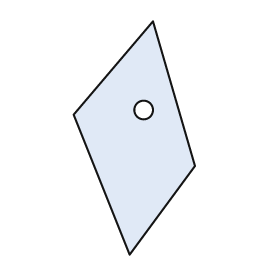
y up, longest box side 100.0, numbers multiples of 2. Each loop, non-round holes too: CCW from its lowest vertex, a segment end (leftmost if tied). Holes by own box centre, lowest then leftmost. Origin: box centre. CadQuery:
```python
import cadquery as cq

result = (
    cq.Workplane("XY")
    .moveTo(-2.0, -50.0)
    .lineTo(26.0, -12.0)
    .lineTo(8.0, 50.0)
    .lineTo(-26.0, 10.0)
    .close()
    .moveTo(4.0, 12.0)
    .circle(4.0)
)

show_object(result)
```